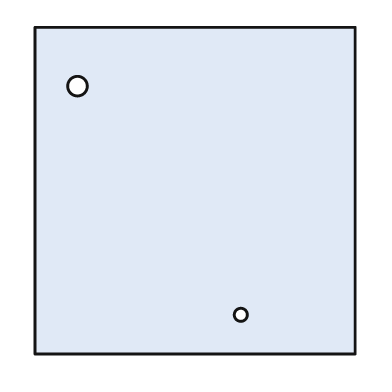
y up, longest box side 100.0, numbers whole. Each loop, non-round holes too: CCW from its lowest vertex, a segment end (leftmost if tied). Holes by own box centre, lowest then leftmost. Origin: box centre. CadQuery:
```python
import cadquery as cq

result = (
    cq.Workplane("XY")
    .moveTo(-49.0, -50.0)
    .lineTo(49.0, -50.0)
    .lineTo(49.0, 50.0)
    .lineTo(-49.0, 50.0)
    .close()
    .moveTo(14.0, -38.0)
    .circle(2.0)
    .moveTo(-36.0, 32.0)
    .circle(3.0)
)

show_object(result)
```